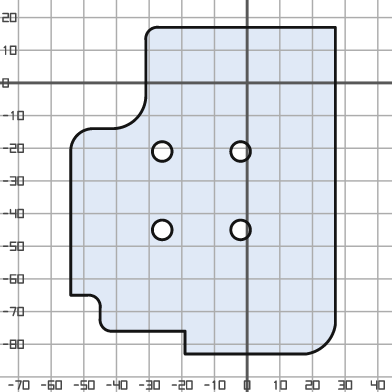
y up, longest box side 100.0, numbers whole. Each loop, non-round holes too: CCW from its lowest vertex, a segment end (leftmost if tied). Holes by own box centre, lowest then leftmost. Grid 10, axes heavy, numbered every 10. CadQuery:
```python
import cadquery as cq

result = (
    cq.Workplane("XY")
    .moveTo(-19.0, -83.0)
    .lineTo(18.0, -83.0)
    .threePointArc((24.0, -80.0), (27.0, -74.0))
    .lineTo(27.0, 17.0)
    .lineTo(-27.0, 17.0)
    .threePointArc((-30.0, 16.0), (-31.0, 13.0))
    .lineTo(-31.0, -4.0)
    .threePointArc((-34.0, -11.0), (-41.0, -14.0))
    .lineTo(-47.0, -14.0)
    .threePointArc((-52.0, -16.0), (-54.0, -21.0))
    .lineTo(-54.0, -65.0)
    .lineTo(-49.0, -65.0)
    .threePointArc((-46.0, -66.0), (-45.0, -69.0))
    .lineTo(-45.0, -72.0)
    .threePointArc((-44.0, -75.0), (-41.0, -76.0))
    .lineTo(-19.0, -76.0)
    .close()
    .moveTo(-26.0, -45.0)
    .circle(3.0)
    .moveTo(-2.0, -45.0)
    .circle(3.0)
    .moveTo(-26.0, -21.0)
    .circle(3.0)
    .moveTo(-2.0, -21.0)
    .circle(3.0)
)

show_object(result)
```